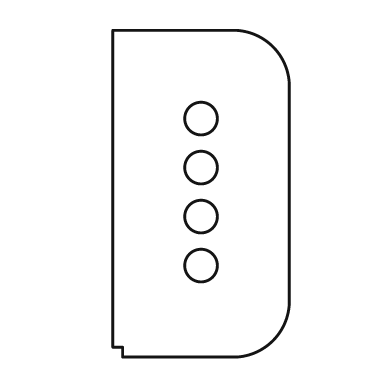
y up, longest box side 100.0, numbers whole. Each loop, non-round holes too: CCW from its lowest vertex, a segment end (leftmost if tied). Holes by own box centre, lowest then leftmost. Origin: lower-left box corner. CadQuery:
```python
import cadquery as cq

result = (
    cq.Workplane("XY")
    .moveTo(3.0, 0.0)
    .lineTo(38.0, 0.0)
    .threePointArc((49.0, 5.0), (54.0, 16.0))
    .lineTo(54.0, 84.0)
    .threePointArc((49.0, 95.0), (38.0, 100.0))
    .lineTo(0.0, 100.0)
    .lineTo(0.0, 3.0)
    .lineTo(3.0, 3.0)
    .close()
    .moveTo(27.0, 28.0)
    .circle(5.0)
    .moveTo(27.0, 43.0)
    .circle(5.0)
    .moveTo(27.0, 58.0)
    .circle(5.0)
    .moveTo(27.0, 73.0)
    .circle(5.0)
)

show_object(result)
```